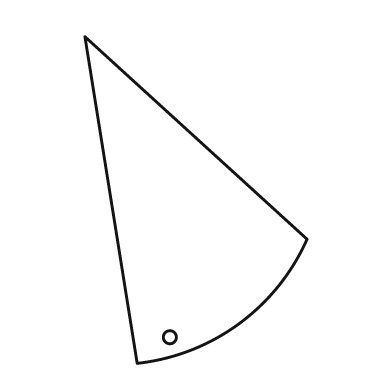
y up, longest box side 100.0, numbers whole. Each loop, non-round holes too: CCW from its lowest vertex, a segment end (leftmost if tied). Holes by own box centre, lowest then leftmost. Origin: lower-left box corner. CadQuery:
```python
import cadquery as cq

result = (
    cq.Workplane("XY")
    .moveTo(16.0, 0.0)
    .threePointArc((47.0, 12.0), (68.0, 38.0))
    .lineTo(0.0, 100.0)
    .close()
    .moveTo(26.0, 8.0)
    .circle(2.0)
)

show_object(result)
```